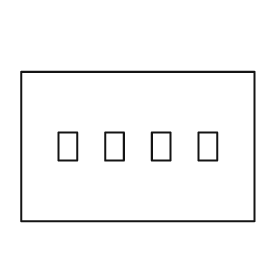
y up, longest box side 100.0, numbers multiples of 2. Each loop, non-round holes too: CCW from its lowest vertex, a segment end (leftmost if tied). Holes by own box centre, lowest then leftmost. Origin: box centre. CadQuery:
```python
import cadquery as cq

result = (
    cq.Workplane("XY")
    .moveTo(-50.0, -32.0)
    .lineTo(50.0, -32.0)
    .lineTo(50.0, 32.0)
    .lineTo(-50.0, 32.0)
    .close()
    .moveTo(-34.0, -6.0)
    .lineTo(-26.0, -6.0)
    .lineTo(-26.0, 6.0)
    .lineTo(-34.0, 6.0)
    .close()
    .moveTo(-14.0, -6.0)
    .lineTo(-6.0, -6.0)
    .lineTo(-6.0, 6.0)
    .lineTo(-14.0, 6.0)
    .close()
    .moveTo(6.0, -6.0)
    .lineTo(14.0, -6.0)
    .lineTo(14.0, 6.0)
    .lineTo(6.0, 6.0)
    .close()
    .moveTo(26.0, -6.0)
    .lineTo(34.0, -6.0)
    .lineTo(34.0, 6.0)
    .lineTo(26.0, 6.0)
    .close()
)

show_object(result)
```